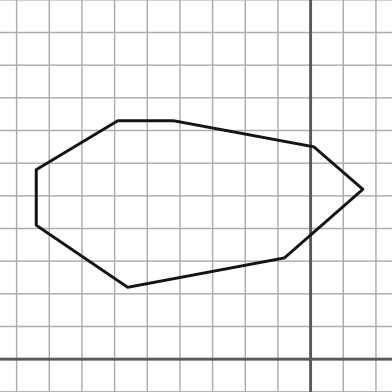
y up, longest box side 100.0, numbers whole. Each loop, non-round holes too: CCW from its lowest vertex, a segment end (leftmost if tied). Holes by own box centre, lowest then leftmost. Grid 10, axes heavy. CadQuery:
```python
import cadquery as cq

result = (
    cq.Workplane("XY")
    .moveTo(-56.0, 22.0)
    .lineTo(-8.0, 31.0)
    .lineTo(16.0, 52.0)
    .lineTo(1.0, 65.0)
    .lineTo(-42.0, 73.0)
    .lineTo(-59.0, 73.0)
    .lineTo(-84.0, 58.0)
    .lineTo(-84.0, 41.0)
    .close()
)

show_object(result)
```